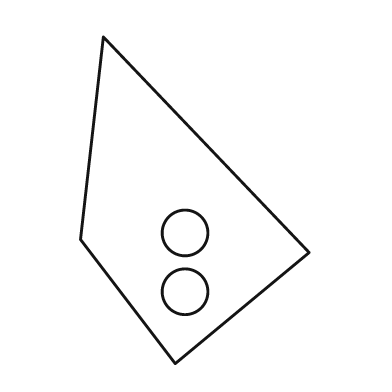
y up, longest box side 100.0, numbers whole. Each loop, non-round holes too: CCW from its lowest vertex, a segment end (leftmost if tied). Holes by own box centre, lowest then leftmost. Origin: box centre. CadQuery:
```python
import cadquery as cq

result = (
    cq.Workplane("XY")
    .moveTo(-6.0, -50.0)
    .lineTo(35.0, -16.0)
    .lineTo(-28.0, 50.0)
    .lineTo(-35.0, -12.0)
    .close()
    .moveTo(-3.0, -28.0)
    .circle(7.0)
    .moveTo(-3.0, -10.0)
    .circle(7.0)
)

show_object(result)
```